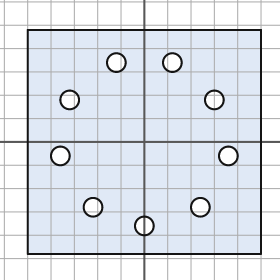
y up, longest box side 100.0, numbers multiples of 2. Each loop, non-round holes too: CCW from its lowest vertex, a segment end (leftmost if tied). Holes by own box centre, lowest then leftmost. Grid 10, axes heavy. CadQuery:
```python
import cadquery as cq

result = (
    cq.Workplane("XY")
    .moveTo(-50.0, -48.0)
    .lineTo(50.0, -48.0)
    .lineTo(50.0, 48.0)
    .lineTo(-50.0, 48.0)
    .close()
    .moveTo(0.0, -36.0)
    .circle(4.0)
    .moveTo(-22.0, -28.0)
    .circle(4.0)
    .moveTo(24.0, -28.0)
    .circle(4.0)
    .moveTo(-36.0, -6.0)
    .circle(4.0)
    .moveTo(36.0, -6.0)
    .circle(4.0)
    .moveTo(-32.0, 18.0)
    .circle(4.0)
    .moveTo(30.0, 18.0)
    .circle(4.0)
    .moveTo(-12.0, 34.0)
    .circle(4.0)
    .moveTo(12.0, 34.0)
    .circle(4.0)
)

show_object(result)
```